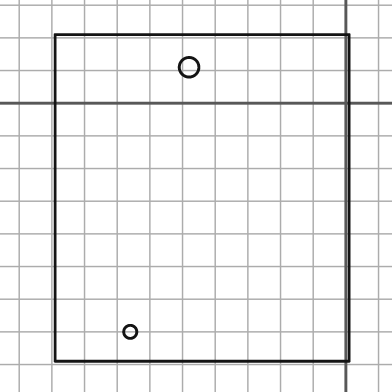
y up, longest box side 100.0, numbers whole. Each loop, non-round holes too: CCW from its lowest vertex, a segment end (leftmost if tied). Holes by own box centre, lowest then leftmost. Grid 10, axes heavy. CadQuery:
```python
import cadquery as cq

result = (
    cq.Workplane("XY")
    .moveTo(-89.0, -79.0)
    .lineTo(1.0, -79.0)
    .lineTo(1.0, 21.0)
    .lineTo(-89.0, 21.0)
    .close()
    .moveTo(-66.0, -70.0)
    .circle(2.0)
    .moveTo(-48.0, 11.0)
    .circle(3.0)
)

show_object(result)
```